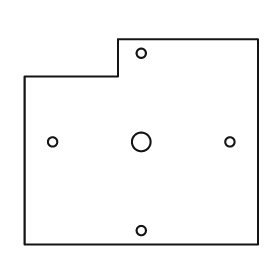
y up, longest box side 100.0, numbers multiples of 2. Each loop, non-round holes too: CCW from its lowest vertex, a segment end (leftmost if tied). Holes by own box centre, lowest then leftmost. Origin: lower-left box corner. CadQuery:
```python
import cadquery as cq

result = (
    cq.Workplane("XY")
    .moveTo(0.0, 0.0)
    .lineTo(100.0, 0.0)
    .lineTo(100.0, 88.0)
    .lineTo(40.0, 88.0)
    .lineTo(40.0, 72.0)
    .lineTo(0.0, 72.0)
    .close()
    .moveTo(50.0, 6.0)
    .circle(2.0)
    .moveTo(12.0, 44.0)
    .circle(2.0)
    .moveTo(50.0, 44.0)
    .circle(4.0)
    .moveTo(88.0, 44.0)
    .circle(2.0)
    .moveTo(50.0, 82.0)
    .circle(2.0)
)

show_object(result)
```